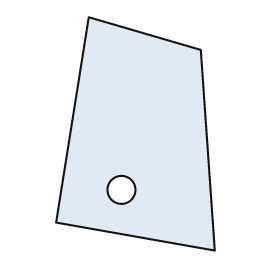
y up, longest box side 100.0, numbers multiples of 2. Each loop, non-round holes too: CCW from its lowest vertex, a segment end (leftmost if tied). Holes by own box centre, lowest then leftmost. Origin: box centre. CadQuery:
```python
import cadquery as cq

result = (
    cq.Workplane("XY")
    .moveTo(34.0, -50.0)
    .lineTo(28.0, 36.0)
    .lineTo(-20.0, 50.0)
    .lineTo(-34.0, -38.0)
    .close()
    .moveTo(-6.0, -24.0)
    .circle(6.0)
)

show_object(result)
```